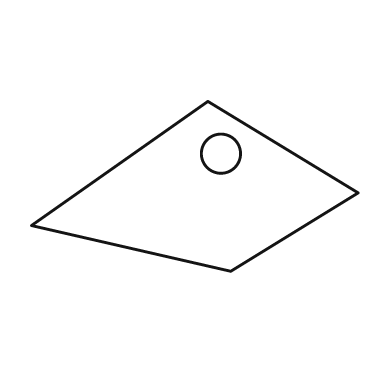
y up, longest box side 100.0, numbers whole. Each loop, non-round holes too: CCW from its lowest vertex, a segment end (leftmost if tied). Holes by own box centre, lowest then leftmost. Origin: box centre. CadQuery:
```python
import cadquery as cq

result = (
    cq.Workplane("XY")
    .moveTo(11.0, -26.0)
    .lineTo(50.0, -2.0)
    .lineTo(4.0, 26.0)
    .lineTo(-50.0, -12.0)
    .close()
    .moveTo(8.0, 10.0)
    .circle(6.0)
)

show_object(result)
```